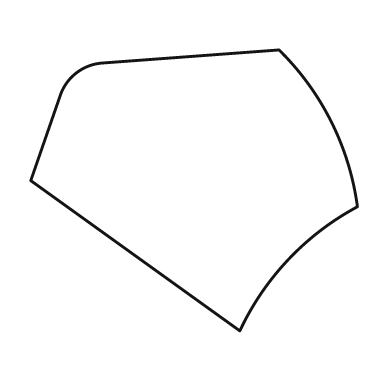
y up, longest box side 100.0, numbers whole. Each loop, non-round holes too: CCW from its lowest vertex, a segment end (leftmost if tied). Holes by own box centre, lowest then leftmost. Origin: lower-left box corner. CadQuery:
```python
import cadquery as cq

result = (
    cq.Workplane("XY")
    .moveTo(64.0, 0.0)
    .threePointArc((79.0, 22.0), (100.0, 38.0))
    .threePointArc((92.0, 64.0), (76.0, 86.0))
    .lineTo(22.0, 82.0)
    .threePointArc((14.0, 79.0), (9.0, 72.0))
    .lineTo(0.0, 46.0)
    .close()
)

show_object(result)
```